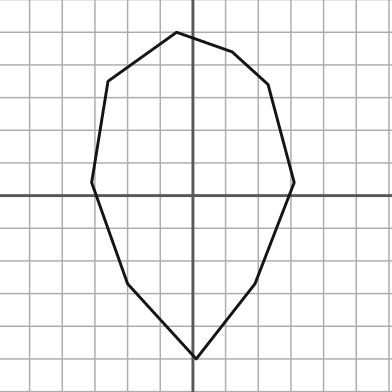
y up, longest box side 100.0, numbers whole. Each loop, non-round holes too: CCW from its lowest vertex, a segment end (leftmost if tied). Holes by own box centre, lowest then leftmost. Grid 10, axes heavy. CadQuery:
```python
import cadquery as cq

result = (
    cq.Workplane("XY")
    .moveTo(1.0, -50.0)
    .lineTo(19.0, -27.0)
    .lineTo(31.0, 4.0)
    .lineTo(23.0, 34.0)
    .lineTo(12.0, 44.0)
    .lineTo(-5.0, 50.0)
    .lineTo(-26.0, 35.0)
    .lineTo(-31.0, 4.0)
    .lineTo(-20.0, -27.0)
    .close()
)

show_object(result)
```